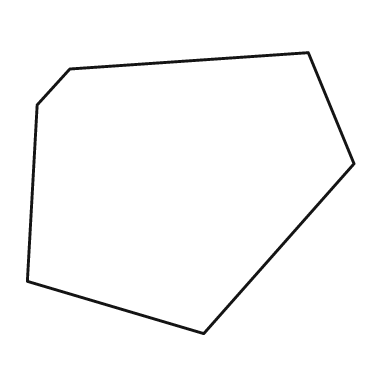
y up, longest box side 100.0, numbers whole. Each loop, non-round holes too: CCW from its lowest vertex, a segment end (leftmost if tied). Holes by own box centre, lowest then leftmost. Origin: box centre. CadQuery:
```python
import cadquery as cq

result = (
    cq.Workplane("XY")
    .moveTo(4.0, -43.0)
    .lineTo(50.0, 9.0)
    .lineTo(36.0, 43.0)
    .lineTo(-37.0, 38.0)
    .lineTo(-47.0, 27.0)
    .lineTo(-50.0, -27.0)
    .close()
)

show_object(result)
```